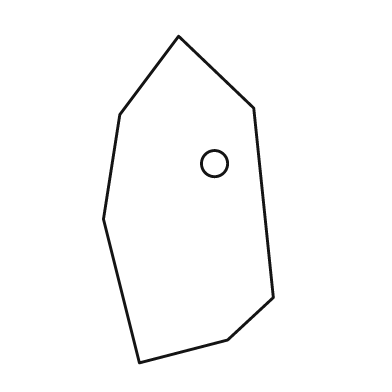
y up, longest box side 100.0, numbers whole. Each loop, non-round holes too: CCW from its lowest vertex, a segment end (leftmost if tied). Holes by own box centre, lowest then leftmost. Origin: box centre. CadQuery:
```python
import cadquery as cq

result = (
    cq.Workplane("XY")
    .moveTo(-15.0, -50.0)
    .lineTo(12.0, -43.0)
    .lineTo(26.0, -30.0)
    .lineTo(20.0, 28.0)
    .lineTo(-3.0, 50.0)
    .lineTo(-21.0, 26.0)
    .lineTo(-26.0, -6.0)
    .close()
    .moveTo(8.0, 11.0)
    .circle(4.0)
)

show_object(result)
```